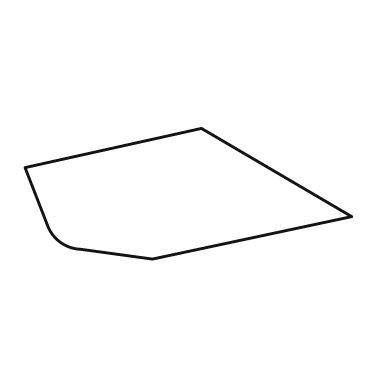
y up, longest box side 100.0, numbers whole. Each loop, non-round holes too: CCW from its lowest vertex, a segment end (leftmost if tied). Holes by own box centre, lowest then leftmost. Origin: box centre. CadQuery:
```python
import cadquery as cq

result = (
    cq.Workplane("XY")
    .moveTo(-11.0, -20.0)
    .lineTo(50.0, -7.0)
    .lineTo(4.0, 20.0)
    .lineTo(-50.0, 8.0)
    .lineTo(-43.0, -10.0)
    .threePointArc((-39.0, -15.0), (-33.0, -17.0))
    .close()
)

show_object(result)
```